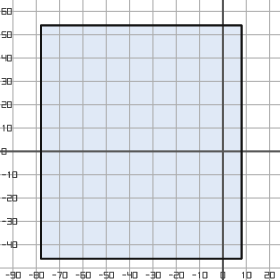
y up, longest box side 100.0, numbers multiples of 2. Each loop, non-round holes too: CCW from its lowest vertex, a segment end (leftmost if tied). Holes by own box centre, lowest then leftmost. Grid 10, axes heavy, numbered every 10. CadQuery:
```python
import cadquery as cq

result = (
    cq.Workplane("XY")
    .moveTo(-78.0, -46.0)
    .lineTo(8.0, -46.0)
    .lineTo(8.0, 54.0)
    .lineTo(-78.0, 54.0)
    .close()
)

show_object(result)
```